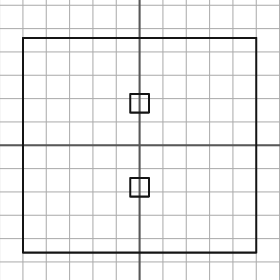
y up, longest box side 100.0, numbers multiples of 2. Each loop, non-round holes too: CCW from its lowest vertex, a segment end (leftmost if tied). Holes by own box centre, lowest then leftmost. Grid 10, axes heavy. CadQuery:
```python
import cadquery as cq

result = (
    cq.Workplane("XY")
    .moveTo(-50.0, -46.0)
    .lineTo(50.0, -46.0)
    .lineTo(50.0, 46.0)
    .lineTo(-50.0, 46.0)
    .close()
    .moveTo(-4.0, -22.0)
    .lineTo(4.0, -22.0)
    .lineTo(4.0, -14.0)
    .lineTo(-4.0, -14.0)
    .close()
    .moveTo(-4.0, 14.0)
    .lineTo(4.0, 14.0)
    .lineTo(4.0, 22.0)
    .lineTo(-4.0, 22.0)
    .close()
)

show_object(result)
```